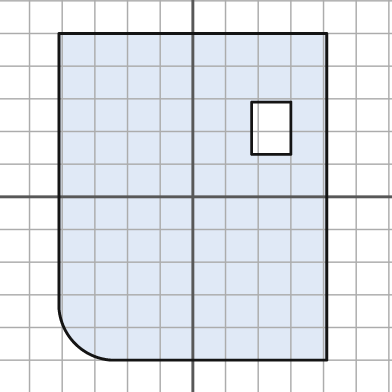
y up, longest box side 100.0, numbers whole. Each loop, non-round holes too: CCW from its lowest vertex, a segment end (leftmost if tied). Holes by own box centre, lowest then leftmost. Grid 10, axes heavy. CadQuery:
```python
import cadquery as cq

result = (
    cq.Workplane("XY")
    .moveTo(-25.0, -50.0)
    .lineTo(41.0, -50.0)
    .lineTo(41.0, 50.0)
    .lineTo(-41.0, 50.0)
    .lineTo(-41.0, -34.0)
    .threePointArc((-36.0, -45.0), (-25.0, -50.0))
    .close()
    .moveTo(18.0, 13.0)
    .lineTo(30.0, 13.0)
    .lineTo(30.0, 29.0)
    .lineTo(18.0, 29.0)
    .close()
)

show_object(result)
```